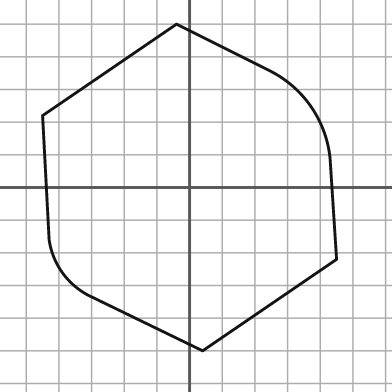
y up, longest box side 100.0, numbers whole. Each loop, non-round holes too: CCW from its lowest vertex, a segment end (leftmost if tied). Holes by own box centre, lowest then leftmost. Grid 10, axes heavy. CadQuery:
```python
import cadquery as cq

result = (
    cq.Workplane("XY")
    .moveTo(4.0, -50.0)
    .lineTo(45.0, -22.0)
    .lineTo(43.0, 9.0)
    .threePointArc((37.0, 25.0), (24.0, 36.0))
    .lineTo(-4.0, 50.0)
    .lineTo(-45.0, 22.0)
    .lineTo(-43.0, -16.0)
    .threePointArc((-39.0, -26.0), (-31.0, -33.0))
    .close()
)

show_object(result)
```